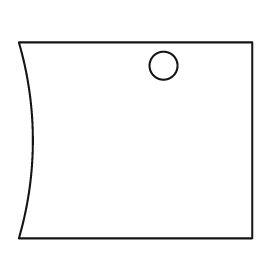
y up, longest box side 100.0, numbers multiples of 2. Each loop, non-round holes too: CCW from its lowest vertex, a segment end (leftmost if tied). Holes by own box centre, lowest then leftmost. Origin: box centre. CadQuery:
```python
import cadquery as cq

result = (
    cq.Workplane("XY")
    .moveTo(-50.0, -42.0)
    .lineTo(50.0, -42.0)
    .lineTo(50.0, 42.0)
    .lineTo(-50.0, 42.0)
    .threePointArc((-44.0, 0.0), (-50.0, -42.0))
    .close()
    .moveTo(12.0, 32.0)
    .circle(6.0)
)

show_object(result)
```